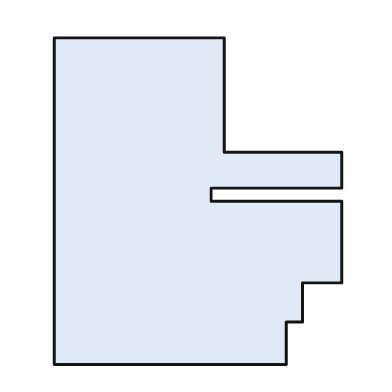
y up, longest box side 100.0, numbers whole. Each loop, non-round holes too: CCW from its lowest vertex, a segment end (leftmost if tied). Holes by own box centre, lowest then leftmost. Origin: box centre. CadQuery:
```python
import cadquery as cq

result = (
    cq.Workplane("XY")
    .moveTo(-44.0, -50.0)
    .lineTo(27.0, -50.0)
    .lineTo(27.0, -37.0)
    .lineTo(32.0, -37.0)
    .lineTo(32.0, -25.0)
    .lineTo(44.0, -25.0)
    .lineTo(44.0, 0.0)
    .lineTo(4.0, 0.0)
    .lineTo(4.0, 4.0)
    .lineTo(44.0, 4.0)
    .lineTo(44.0, 15.0)
    .lineTo(8.0, 15.0)
    .lineTo(8.0, 50.0)
    .lineTo(-44.0, 50.0)
    .close()
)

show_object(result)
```